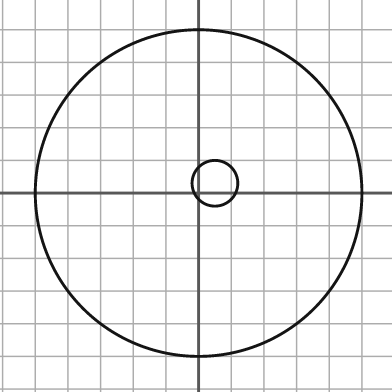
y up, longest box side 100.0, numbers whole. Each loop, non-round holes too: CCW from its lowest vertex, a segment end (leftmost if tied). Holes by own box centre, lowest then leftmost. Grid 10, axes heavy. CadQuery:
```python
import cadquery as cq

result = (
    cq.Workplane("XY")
    .moveTo(0.0, 0.0)
    .circle(50.0)
    .moveTo(5.0, 3.0)
    .circle(7.0)
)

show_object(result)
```